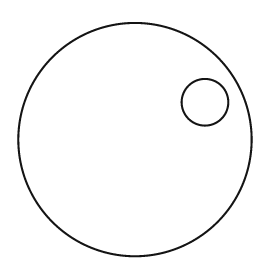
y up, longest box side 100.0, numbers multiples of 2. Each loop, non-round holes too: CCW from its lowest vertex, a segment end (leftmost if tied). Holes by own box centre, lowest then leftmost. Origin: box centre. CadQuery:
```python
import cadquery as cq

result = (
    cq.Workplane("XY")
    .moveTo(0.0, 0.0)
    .circle(50.0)
    .moveTo(30.0, 16.0)
    .circle(10.0)
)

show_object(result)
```